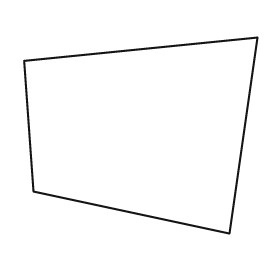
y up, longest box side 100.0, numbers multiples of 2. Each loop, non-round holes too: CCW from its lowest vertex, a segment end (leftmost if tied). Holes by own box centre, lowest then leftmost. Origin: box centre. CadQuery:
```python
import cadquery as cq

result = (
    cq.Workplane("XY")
    .moveTo(38.0, -42.0)
    .lineTo(50.0, 42.0)
    .lineTo(-50.0, 32.0)
    .lineTo(-46.0, -24.0)
    .close()
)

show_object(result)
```